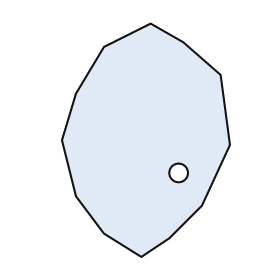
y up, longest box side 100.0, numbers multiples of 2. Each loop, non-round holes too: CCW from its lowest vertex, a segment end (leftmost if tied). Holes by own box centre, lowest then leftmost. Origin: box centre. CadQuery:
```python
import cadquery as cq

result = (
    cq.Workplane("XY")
    .moveTo(-2.0, -50.0)
    .lineTo(10.0, -42.0)
    .lineTo(24.0, -28.0)
    .lineTo(36.0, -2.0)
    .lineTo(32.0, 28.0)
    .lineTo(16.0, 42.0)
    .lineTo(2.0, 50.0)
    .lineTo(-18.0, 40.0)
    .lineTo(-30.0, 20.0)
    .lineTo(-36.0, 0.0)
    .lineTo(-30.0, -24.0)
    .lineTo(-18.0, -40.0)
    .close()
    .moveTo(14.0, -14.0)
    .circle(4.0)
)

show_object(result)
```